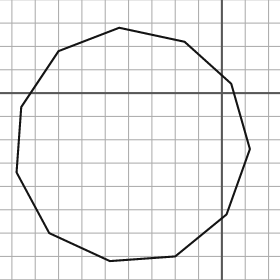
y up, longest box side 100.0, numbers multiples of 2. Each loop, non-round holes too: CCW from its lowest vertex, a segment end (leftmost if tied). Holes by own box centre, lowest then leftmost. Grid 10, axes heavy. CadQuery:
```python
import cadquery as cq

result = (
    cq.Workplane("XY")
    .moveTo(-48.0, -72.0)
    .lineTo(-20.0, -70.0)
    .lineTo(2.0, -52.0)
    .lineTo(12.0, -24.0)
    .lineTo(4.0, 4.0)
    .lineTo(-16.0, 22.0)
    .lineTo(-44.0, 28.0)
    .lineTo(-70.0, 18.0)
    .lineTo(-86.0, -6.0)
    .lineTo(-88.0, -34.0)
    .lineTo(-74.0, -60.0)
    .close()
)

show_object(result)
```